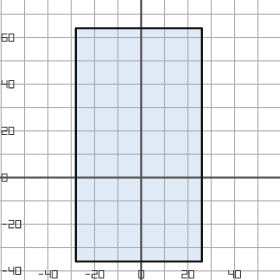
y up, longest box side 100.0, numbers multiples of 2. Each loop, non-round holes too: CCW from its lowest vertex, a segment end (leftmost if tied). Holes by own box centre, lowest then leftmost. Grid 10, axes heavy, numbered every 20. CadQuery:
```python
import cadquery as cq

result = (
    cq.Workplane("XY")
    .moveTo(-28.0, -36.0)
    .lineTo(26.0, -36.0)
    .lineTo(26.0, 64.0)
    .lineTo(-28.0, 64.0)
    .close()
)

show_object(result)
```